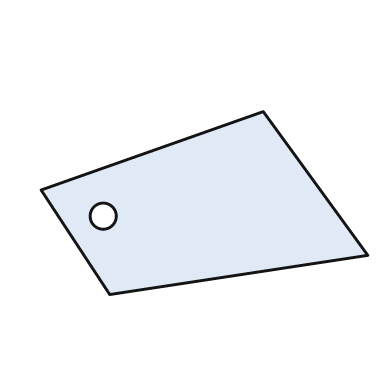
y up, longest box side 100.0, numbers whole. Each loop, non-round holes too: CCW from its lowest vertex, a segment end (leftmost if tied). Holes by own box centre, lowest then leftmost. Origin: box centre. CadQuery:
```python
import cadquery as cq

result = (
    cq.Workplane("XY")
    .moveTo(-29.0, -28.0)
    .lineTo(50.0, -16.0)
    .lineTo(18.0, 28.0)
    .lineTo(-50.0, 4.0)
    .close()
    .moveTo(-31.0, -4.0)
    .circle(4.0)
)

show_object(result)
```